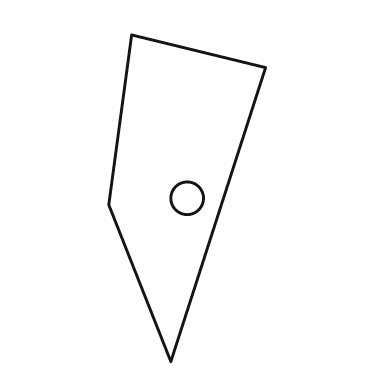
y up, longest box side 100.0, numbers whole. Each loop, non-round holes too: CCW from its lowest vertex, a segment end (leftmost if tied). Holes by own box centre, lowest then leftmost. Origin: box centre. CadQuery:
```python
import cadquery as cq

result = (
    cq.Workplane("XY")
    .moveTo(-5.0, -50.0)
    .lineTo(24.0, 40.0)
    .lineTo(-17.0, 50.0)
    .lineTo(-24.0, -2.0)
    .close()
    .moveTo(0.0, 0.0)
    .circle(5.0)
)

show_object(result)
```